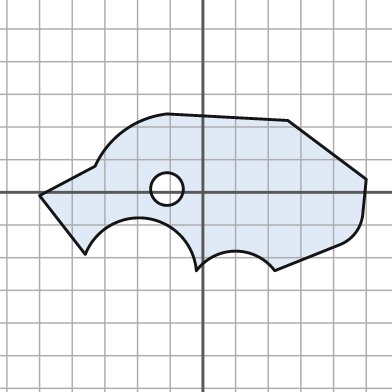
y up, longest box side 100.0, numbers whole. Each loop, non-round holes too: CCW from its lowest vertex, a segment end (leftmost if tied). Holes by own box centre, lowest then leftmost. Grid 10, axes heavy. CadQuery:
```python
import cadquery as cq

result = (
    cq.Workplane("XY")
    .moveTo(-2.0, -24.0)
    .threePointArc((10.0, -18.0), (22.0, -24.0))
    .lineTo(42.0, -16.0)
    .threePointArc((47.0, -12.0), (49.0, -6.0))
    .lineTo(50.0, 4.0)
    .lineTo(26.0, 22.0)
    .lineTo(-11.0, 24.0)
    .threePointArc((-24.0, 19.0), (-33.0, 8.0))
    .lineTo(-50.0, -1.0)
    .lineTo(-36.0, -19.0)
    .threePointArc((-17.0, -8.0), (-2.0, -24.0))
    .close()
    .moveTo(-11.0, 1.0)
    .circle(5.0)
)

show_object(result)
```